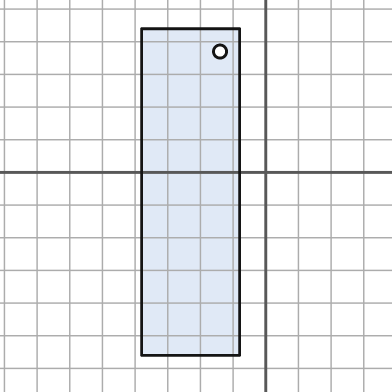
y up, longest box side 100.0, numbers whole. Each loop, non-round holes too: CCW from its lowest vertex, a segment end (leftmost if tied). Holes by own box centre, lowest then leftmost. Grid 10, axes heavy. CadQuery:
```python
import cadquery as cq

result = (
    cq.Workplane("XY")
    .moveTo(-38.0, -56.0)
    .lineTo(-8.0, -56.0)
    .lineTo(-8.0, 44.0)
    .lineTo(-38.0, 44.0)
    .close()
    .moveTo(-14.0, 37.0)
    .circle(2.0)
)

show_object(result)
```